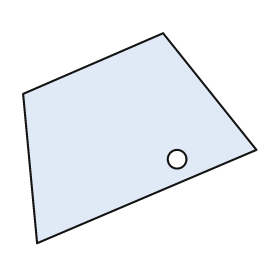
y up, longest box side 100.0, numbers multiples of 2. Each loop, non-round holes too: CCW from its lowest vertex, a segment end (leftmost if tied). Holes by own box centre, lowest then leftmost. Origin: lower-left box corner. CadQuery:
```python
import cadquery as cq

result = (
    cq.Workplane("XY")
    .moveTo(6.0, 0.0)
    .lineTo(100.0, 40.0)
    .lineTo(60.0, 90.0)
    .lineTo(0.0, 64.0)
    .close()
    .moveTo(66.0, 36.0)
    .circle(4.0)
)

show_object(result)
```